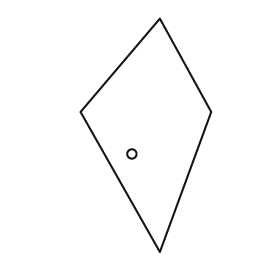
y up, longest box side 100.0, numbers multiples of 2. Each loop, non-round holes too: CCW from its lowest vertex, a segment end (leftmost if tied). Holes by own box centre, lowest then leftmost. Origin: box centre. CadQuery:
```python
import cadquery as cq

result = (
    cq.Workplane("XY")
    .moveTo(6.0, -50.0)
    .lineTo(28.0, 10.0)
    .lineTo(6.0, 50.0)
    .lineTo(-28.0, 10.0)
    .close()
    .moveTo(-6.0, -8.0)
    .circle(2.0)
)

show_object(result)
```